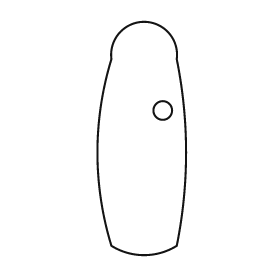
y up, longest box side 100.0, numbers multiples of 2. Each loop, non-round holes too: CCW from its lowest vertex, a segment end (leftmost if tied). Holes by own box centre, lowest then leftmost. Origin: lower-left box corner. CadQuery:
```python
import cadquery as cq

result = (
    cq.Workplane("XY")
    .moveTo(6.0, 4.0)
    .threePointArc((20.0, 0.0), (34.0, 4.0))
    .threePointArc((38.0, 44.0), (34.0, 84.0))
    .threePointArc((20.0, 100.0), (6.0, 84.0))
    .threePointArc((0.0, 44.0), (6.0, 4.0))
    .close()
    .moveTo(28.0, 62.0)
    .circle(4.0)
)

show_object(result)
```